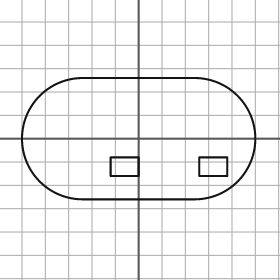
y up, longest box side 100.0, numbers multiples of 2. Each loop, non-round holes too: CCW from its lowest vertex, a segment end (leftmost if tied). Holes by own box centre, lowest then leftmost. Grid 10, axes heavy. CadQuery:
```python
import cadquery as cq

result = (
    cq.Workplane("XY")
    .moveTo(-24.0, -26.0)
    .lineTo(24.0, -26.0)
    .threePointArc((50.0, 0.0), (24.0, 26.0))
    .lineTo(-24.0, 26.0)
    .threePointArc((-50.0, 0.0), (-24.0, -26.0))
    .close()
    .moveTo(-12.0, -16.0)
    .lineTo(0.0, -16.0)
    .lineTo(0.0, -8.0)
    .lineTo(-12.0, -8.0)
    .close()
    .moveTo(26.0, -16.0)
    .lineTo(38.0, -16.0)
    .lineTo(38.0, -8.0)
    .lineTo(26.0, -8.0)
    .close()
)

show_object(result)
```